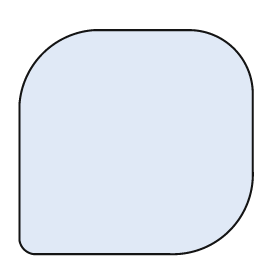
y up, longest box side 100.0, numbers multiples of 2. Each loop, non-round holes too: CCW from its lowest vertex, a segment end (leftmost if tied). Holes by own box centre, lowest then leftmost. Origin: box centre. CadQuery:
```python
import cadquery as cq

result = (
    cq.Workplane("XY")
    .moveTo(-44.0, -48.0)
    .lineTo(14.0, -48.0)
    .threePointArc((40.0, -38.0), (50.0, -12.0))
    .lineTo(50.0, 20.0)
    .threePointArc((42.0, 40.0), (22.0, 48.0))
    .lineTo(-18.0, 48.0)
    .threePointArc((-40.0, 38.0), (-50.0, 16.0))
    .lineTo(-50.0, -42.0)
    .threePointArc((-48.0, -46.0), (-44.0, -48.0))
    .close()
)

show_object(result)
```